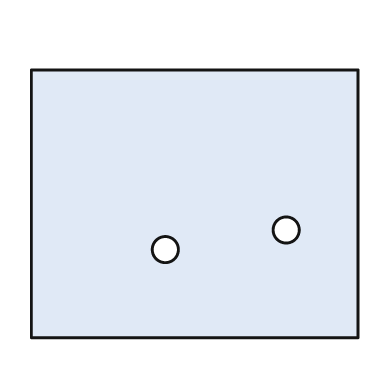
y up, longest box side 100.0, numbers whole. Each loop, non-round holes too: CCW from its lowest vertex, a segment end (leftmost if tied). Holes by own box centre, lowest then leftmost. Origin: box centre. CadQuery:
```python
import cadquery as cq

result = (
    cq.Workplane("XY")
    .moveTo(-50.0, -41.0)
    .lineTo(50.0, -41.0)
    .lineTo(50.0, 41.0)
    .lineTo(-50.0, 41.0)
    .close()
    .moveTo(-9.0, -14.0)
    .circle(4.0)
    .moveTo(28.0, -8.0)
    .circle(4.0)
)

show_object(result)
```